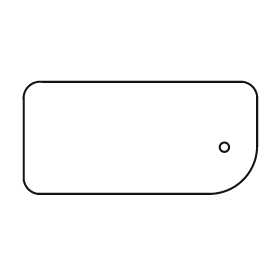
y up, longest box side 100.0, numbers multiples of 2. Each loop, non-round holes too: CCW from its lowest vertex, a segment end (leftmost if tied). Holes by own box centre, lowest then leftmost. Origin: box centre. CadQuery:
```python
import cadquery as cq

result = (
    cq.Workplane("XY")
    .moveTo(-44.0, -24.0)
    .lineTo(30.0, -24.0)
    .threePointArc((44.0, -18.0), (50.0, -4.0))
    .lineTo(50.0, 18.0)
    .threePointArc((48.0, 22.0), (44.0, 24.0))
    .lineTo(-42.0, 24.0)
    .threePointArc((-48.0, 22.0), (-50.0, 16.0))
    .lineTo(-50.0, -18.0)
    .threePointArc((-48.0, -22.0), (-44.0, -24.0))
    .close()
    .moveTo(36.0, -4.0)
    .circle(2.0)
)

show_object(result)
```